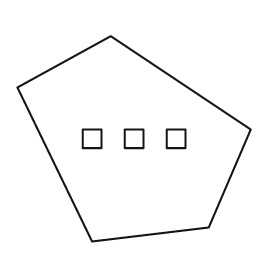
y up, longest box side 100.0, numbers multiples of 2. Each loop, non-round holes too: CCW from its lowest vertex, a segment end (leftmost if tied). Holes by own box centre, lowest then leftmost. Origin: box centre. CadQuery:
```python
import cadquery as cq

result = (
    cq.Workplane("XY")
    .moveTo(-18.0, -44.0)
    .lineTo(32.0, -38.0)
    .lineTo(50.0, 4.0)
    .lineTo(-10.0, 44.0)
    .lineTo(-50.0, 22.0)
    .close()
    .moveTo(-22.0, -4.0)
    .lineTo(-14.0, -4.0)
    .lineTo(-14.0, 4.0)
    .lineTo(-22.0, 4.0)
    .close()
    .moveTo(-4.0, -4.0)
    .lineTo(4.0, -4.0)
    .lineTo(4.0, 4.0)
    .lineTo(-4.0, 4.0)
    .close()
    .moveTo(14.0, -4.0)
    .lineTo(22.0, -4.0)
    .lineTo(22.0, 4.0)
    .lineTo(14.0, 4.0)
    .close()
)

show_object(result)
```